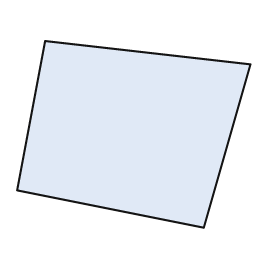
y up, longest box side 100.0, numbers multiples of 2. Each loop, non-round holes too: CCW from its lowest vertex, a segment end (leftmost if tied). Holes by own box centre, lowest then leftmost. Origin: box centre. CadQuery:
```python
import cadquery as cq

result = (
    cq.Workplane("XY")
    .moveTo(30.0, -40.0)
    .lineTo(50.0, 30.0)
    .lineTo(-38.0, 40.0)
    .lineTo(-50.0, -24.0)
    .close()
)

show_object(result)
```